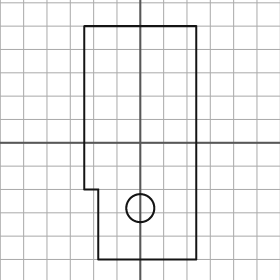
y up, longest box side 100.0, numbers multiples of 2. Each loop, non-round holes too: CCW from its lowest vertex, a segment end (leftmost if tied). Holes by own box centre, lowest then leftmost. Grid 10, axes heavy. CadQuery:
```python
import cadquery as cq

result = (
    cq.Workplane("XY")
    .moveTo(-18.0, -50.0)
    .lineTo(24.0, -50.0)
    .lineTo(24.0, 50.0)
    .lineTo(-24.0, 50.0)
    .lineTo(-24.0, -20.0)
    .lineTo(-18.0, -20.0)
    .close()
    .moveTo(0.0, -28.0)
    .circle(6.0)
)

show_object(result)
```